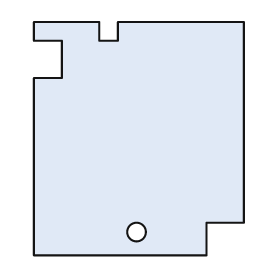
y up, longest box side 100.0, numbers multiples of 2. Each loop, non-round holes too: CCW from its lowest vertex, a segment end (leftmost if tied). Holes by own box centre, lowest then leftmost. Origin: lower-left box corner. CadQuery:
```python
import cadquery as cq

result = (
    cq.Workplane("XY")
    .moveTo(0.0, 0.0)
    .lineTo(74.0, 0.0)
    .lineTo(74.0, 14.0)
    .lineTo(90.0, 14.0)
    .lineTo(90.0, 100.0)
    .lineTo(36.0, 100.0)
    .lineTo(36.0, 92.0)
    .lineTo(28.0, 92.0)
    .lineTo(28.0, 100.0)
    .lineTo(0.0, 100.0)
    .lineTo(0.0, 92.0)
    .lineTo(12.0, 92.0)
    .lineTo(12.0, 76.0)
    .lineTo(0.0, 76.0)
    .close()
    .moveTo(44.0, 10.0)
    .circle(4.0)
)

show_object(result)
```